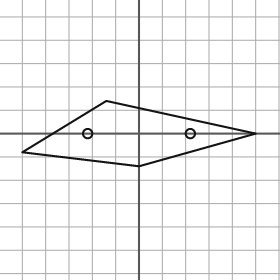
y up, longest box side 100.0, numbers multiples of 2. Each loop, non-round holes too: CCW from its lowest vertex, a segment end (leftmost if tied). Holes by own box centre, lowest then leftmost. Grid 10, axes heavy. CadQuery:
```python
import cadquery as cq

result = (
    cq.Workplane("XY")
    .moveTo(0.0, -14.0)
    .lineTo(50.0, 0.0)
    .lineTo(-14.0, 14.0)
    .lineTo(-50.0, -8.0)
    .close()
    .moveTo(-22.0, 0.0)
    .circle(2.0)
    .moveTo(22.0, 0.0)
    .circle(2.0)
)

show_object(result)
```